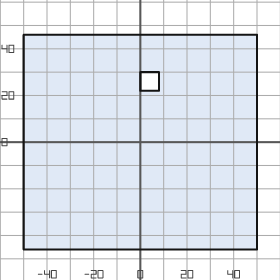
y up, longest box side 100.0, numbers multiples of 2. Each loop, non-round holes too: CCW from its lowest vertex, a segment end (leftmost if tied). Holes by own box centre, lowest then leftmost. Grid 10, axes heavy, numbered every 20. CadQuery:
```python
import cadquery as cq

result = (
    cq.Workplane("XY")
    .moveTo(-50.0, -46.0)
    .lineTo(50.0, -46.0)
    .lineTo(50.0, 46.0)
    .lineTo(-50.0, 46.0)
    .close()
    .moveTo(0.0, 22.0)
    .lineTo(8.0, 22.0)
    .lineTo(8.0, 30.0)
    .lineTo(0.0, 30.0)
    .close()
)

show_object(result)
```